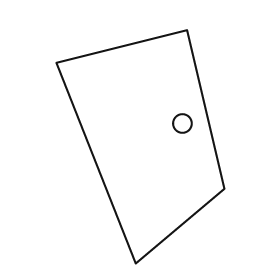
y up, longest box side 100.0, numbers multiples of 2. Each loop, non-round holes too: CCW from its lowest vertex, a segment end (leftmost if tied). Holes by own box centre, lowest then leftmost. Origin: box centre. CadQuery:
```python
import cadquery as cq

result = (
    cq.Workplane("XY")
    .moveTo(-2.0, -50.0)
    .lineTo(36.0, -18.0)
    .lineTo(20.0, 50.0)
    .lineTo(-36.0, 36.0)
    .close()
    .moveTo(18.0, 10.0)
    .circle(4.0)
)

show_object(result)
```